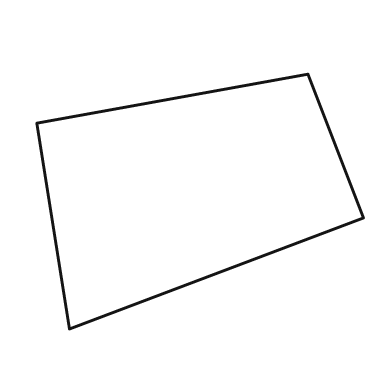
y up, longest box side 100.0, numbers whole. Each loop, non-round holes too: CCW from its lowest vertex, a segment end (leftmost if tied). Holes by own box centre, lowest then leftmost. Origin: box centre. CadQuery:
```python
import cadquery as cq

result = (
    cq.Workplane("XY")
    .moveTo(-40.0, -39.0)
    .lineTo(50.0, -5.0)
    .lineTo(33.0, 39.0)
    .lineTo(-50.0, 24.0)
    .close()
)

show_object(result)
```